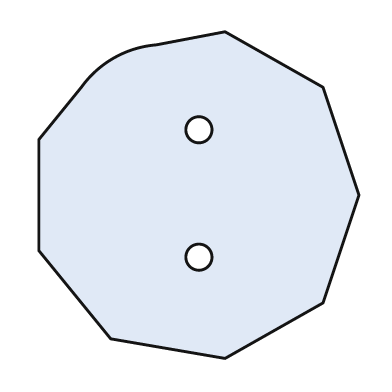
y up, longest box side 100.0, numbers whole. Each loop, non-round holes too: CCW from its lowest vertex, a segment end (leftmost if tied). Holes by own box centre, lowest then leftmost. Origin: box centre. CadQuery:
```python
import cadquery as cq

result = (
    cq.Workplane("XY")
    .moveTo(8.0, -50.0)
    .lineTo(38.0, -33.0)
    .lineTo(49.0, 0.0)
    .lineTo(38.0, 33.0)
    .lineTo(8.0, 50.0)
    .lineTo(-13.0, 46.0)
    .threePointArc((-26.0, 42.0), (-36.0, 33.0))
    .lineTo(-49.0, 17.0)
    .lineTo(-49.0, -17.0)
    .lineTo(-27.0, -44.0)
    .close()
    .moveTo(0.0, -19.0)
    .circle(4.0)
    .moveTo(0.0, 20.0)
    .circle(4.0)
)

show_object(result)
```